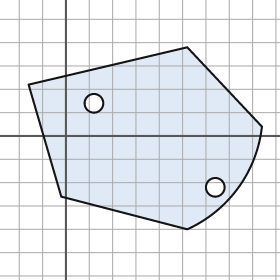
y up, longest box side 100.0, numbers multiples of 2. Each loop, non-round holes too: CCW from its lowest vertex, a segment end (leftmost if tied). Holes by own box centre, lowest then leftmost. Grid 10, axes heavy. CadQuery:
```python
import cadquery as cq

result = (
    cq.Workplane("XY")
    .moveTo(52.0, -40.0)
    .threePointArc((74.0, -22.0), (84.0, 4.0))
    .lineTo(52.0, 38.0)
    .lineTo(-16.0, 22.0)
    .lineTo(-2.0, -26.0)
    .close()
    .moveTo(64.0, -22.0)
    .circle(4.0)
    .moveTo(12.0, 14.0)
    .circle(4.0)
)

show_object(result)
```